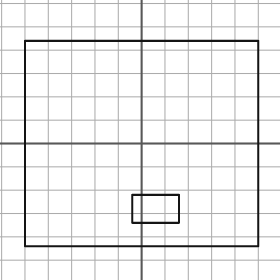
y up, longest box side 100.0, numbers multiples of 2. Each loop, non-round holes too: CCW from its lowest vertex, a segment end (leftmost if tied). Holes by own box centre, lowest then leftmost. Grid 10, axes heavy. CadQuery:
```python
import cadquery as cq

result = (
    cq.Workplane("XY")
    .moveTo(-50.0, -44.0)
    .lineTo(50.0, -44.0)
    .lineTo(50.0, 44.0)
    .lineTo(-50.0, 44.0)
    .close()
    .moveTo(-4.0, -34.0)
    .lineTo(16.0, -34.0)
    .lineTo(16.0, -22.0)
    .lineTo(-4.0, -22.0)
    .close()
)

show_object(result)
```